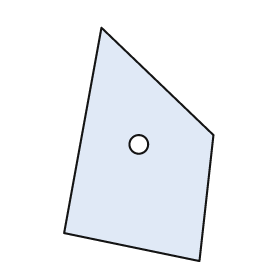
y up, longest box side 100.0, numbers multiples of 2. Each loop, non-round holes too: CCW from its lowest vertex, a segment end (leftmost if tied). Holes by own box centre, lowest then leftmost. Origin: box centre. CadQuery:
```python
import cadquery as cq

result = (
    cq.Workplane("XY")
    .moveTo(26.0, -50.0)
    .lineTo(32.0, 4.0)
    .lineTo(-16.0, 50.0)
    .lineTo(-32.0, -38.0)
    .close()
    .moveTo(0.0, 0.0)
    .circle(4.0)
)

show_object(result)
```